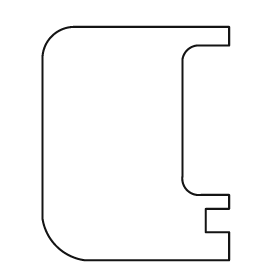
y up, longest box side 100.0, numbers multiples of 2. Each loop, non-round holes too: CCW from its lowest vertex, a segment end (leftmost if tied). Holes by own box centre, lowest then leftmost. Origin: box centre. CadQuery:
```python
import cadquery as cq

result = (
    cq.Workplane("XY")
    .moveTo(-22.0, -50.0)
    .lineTo(40.0, -50.0)
    .lineTo(40.0, -38.0)
    .lineTo(30.0, -38.0)
    .lineTo(30.0, -28.0)
    .lineTo(40.0, -28.0)
    .lineTo(40.0, -22.0)
    .lineTo(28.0, -22.0)
    .threePointArc((22.0, -20.0), (20.0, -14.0))
    .lineTo(20.0, 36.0)
    .threePointArc((22.0, 40.0), (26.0, 42.0))
    .lineTo(40.0, 42.0)
    .lineTo(40.0, 50.0)
    .lineTo(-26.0, 50.0)
    .threePointArc((-36.0, 46.0), (-40.0, 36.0))
    .lineTo(-40.0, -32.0)
    .threePointArc((-34.0, -44.0), (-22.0, -50.0))
    .close()
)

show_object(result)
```